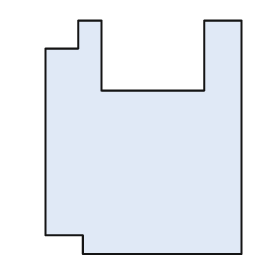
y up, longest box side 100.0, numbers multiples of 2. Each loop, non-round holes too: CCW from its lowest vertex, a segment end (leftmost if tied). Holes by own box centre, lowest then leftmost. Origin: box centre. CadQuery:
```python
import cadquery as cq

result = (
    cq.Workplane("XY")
    .moveTo(-26.0, -50.0)
    .lineTo(42.0, -50.0)
    .lineTo(42.0, 50.0)
    .lineTo(26.0, 50.0)
    .lineTo(26.0, 20.0)
    .lineTo(-18.0, 20.0)
    .lineTo(-18.0, 50.0)
    .lineTo(-28.0, 50.0)
    .lineTo(-28.0, 38.0)
    .lineTo(-42.0, 38.0)
    .lineTo(-42.0, -42.0)
    .lineTo(-26.0, -42.0)
    .close()
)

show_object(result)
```